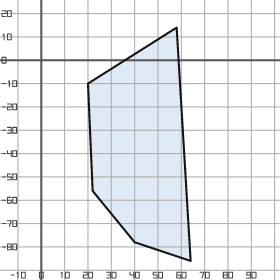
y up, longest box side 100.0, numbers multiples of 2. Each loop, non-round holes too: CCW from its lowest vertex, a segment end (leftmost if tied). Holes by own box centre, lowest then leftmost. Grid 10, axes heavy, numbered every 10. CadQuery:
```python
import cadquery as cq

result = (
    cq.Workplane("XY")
    .moveTo(64.0, -86.0)
    .lineTo(58.0, 14.0)
    .lineTo(20.0, -10.0)
    .lineTo(22.0, -56.0)
    .lineTo(40.0, -78.0)
    .close()
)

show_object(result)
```